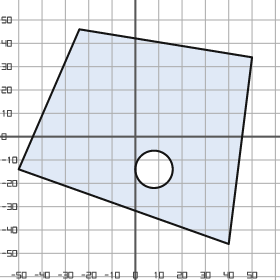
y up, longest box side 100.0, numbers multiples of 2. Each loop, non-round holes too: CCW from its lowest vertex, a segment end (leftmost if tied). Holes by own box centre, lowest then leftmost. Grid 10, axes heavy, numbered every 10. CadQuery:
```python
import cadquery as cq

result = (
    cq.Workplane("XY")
    .moveTo(40.0, -46.0)
    .lineTo(50.0, 34.0)
    .lineTo(-24.0, 46.0)
    .lineTo(-50.0, -14.0)
    .close()
    .moveTo(8.0, -14.0)
    .circle(8.0)
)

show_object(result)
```